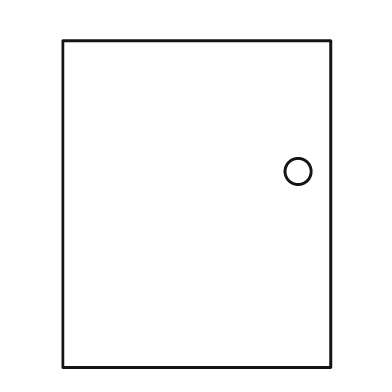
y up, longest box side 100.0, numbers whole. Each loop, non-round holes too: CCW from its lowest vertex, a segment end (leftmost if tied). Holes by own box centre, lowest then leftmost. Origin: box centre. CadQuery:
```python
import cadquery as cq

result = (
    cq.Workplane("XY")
    .moveTo(-41.0, -50.0)
    .lineTo(41.0, -50.0)
    .lineTo(41.0, 50.0)
    .lineTo(-41.0, 50.0)
    .close()
    .moveTo(31.0, 10.0)
    .circle(4.0)
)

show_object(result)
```